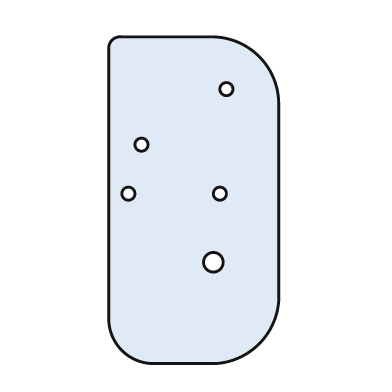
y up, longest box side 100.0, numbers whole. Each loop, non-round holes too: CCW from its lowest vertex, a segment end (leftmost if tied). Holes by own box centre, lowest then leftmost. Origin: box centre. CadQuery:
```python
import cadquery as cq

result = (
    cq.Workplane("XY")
    .moveTo(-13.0, -50.0)
    .lineTo(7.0, -50.0)
    .threePointArc((20.0, -44.0), (26.0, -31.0))
    .lineTo(26.0, 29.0)
    .threePointArc((20.0, 44.0), (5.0, 50.0))
    .lineTo(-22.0, 50.0)
    .threePointArc((-25.0, 49.0), (-26.0, 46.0))
    .lineTo(-26.0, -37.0)
    .threePointArc((-22.0, -46.0), (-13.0, -50.0))
    .close()
    .moveTo(6.0, -19.0)
    .circle(3.0)
    .moveTo(-20.0, 2.0)
    .circle(2.0)
    .moveTo(8.0, 2.0)
    .circle(2.0)
    .moveTo(-16.0, 17.0)
    .circle(2.0)
    .moveTo(10.0, 34.0)
    .circle(2.0)
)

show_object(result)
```